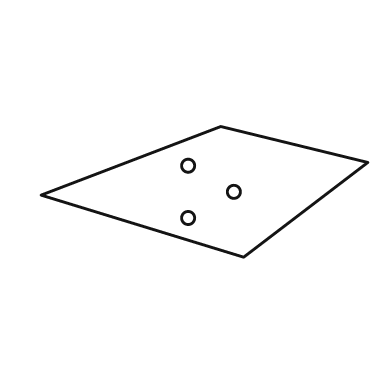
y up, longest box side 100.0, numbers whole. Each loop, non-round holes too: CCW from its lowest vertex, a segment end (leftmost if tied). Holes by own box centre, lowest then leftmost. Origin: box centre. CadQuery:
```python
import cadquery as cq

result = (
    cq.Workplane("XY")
    .moveTo(12.0, -20.0)
    .lineTo(50.0, 9.0)
    .lineTo(5.0, 20.0)
    .lineTo(-50.0, -1.0)
    .close()
    .moveTo(-5.0, -8.0)
    .circle(2.0)
    .moveTo(9.0, 0.0)
    .circle(2.0)
    .moveTo(-5.0, 8.0)
    .circle(2.0)
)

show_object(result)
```